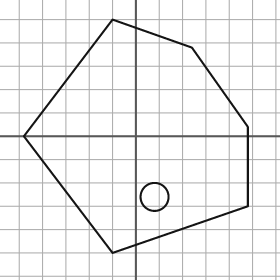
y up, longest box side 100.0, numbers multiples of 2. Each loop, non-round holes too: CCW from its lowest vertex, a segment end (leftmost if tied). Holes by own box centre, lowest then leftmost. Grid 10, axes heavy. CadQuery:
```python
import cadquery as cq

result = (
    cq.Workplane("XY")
    .moveTo(-10.0, -50.0)
    .lineTo(48.0, -30.0)
    .lineTo(48.0, 4.0)
    .lineTo(24.0, 38.0)
    .lineTo(-10.0, 50.0)
    .lineTo(-48.0, 0.0)
    .close()
    .moveTo(8.0, -26.0)
    .circle(6.0)
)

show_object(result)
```